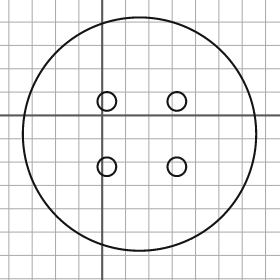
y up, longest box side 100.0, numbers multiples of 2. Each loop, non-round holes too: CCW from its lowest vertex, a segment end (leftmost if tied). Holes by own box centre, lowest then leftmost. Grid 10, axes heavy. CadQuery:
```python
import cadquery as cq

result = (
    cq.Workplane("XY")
    .moveTo(16.0, -8.0)
    .circle(50.0)
    .moveTo(2.0, -22.0)
    .circle(4.0)
    .moveTo(32.0, -22.0)
    .circle(4.0)
    .moveTo(2.0, 6.0)
    .circle(4.0)
    .moveTo(32.0, 6.0)
    .circle(4.0)
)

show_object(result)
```